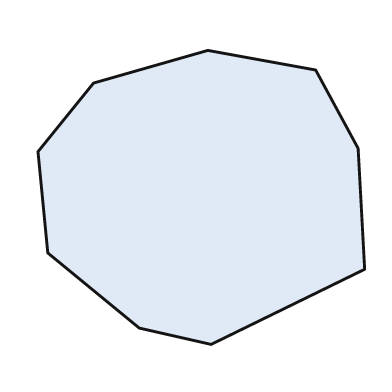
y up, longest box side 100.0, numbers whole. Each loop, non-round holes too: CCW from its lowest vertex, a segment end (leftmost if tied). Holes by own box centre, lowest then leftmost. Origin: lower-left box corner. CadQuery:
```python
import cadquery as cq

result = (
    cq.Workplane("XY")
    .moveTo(53.0, 0.0)
    .lineTo(100.0, 23.0)
    .lineTo(98.0, 60.0)
    .lineTo(85.0, 84.0)
    .lineTo(52.0, 90.0)
    .lineTo(17.0, 80.0)
    .lineTo(0.0, 59.0)
    .lineTo(3.0, 28.0)
    .lineTo(31.0, 5.0)
    .close()
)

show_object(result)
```